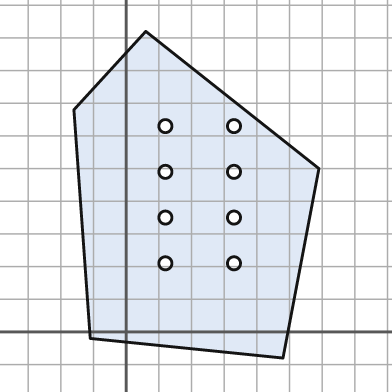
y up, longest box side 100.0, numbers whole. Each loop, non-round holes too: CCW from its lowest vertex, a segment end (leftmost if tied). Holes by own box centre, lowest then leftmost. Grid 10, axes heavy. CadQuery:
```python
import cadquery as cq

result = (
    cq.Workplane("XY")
    .moveTo(48.0, -8.0)
    .lineTo(59.0, 50.0)
    .lineTo(6.0, 92.0)
    .lineTo(-16.0, 68.0)
    .lineTo(-11.0, -2.0)
    .close()
    .moveTo(12.0, 21.0)
    .circle(2.0)
    .moveTo(33.0, 21.0)
    .circle(2.0)
    .moveTo(12.0, 35.0)
    .circle(2.0)
    .moveTo(33.0, 35.0)
    .circle(2.0)
    .moveTo(12.0, 49.0)
    .circle(2.0)
    .moveTo(33.0, 49.0)
    .circle(2.0)
    .moveTo(12.0, 63.0)
    .circle(2.0)
    .moveTo(33.0, 63.0)
    .circle(2.0)
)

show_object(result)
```